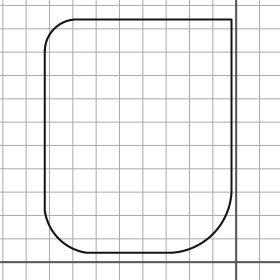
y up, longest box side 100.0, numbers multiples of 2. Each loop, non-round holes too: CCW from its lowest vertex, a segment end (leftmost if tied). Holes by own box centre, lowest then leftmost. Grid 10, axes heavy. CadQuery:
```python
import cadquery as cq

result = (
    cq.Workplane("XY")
    .moveTo(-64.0, 4.0)
    .lineTo(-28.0, 4.0)
    .threePointArc((-10.0, 12.0), (-2.0, 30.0))
    .lineTo(-2.0, 104.0)
    .lineTo(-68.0, 104.0)
    .threePointArc((-78.0, 100.0), (-82.0, 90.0))
    .lineTo(-82.0, 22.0)
    .threePointArc((-76.0, 10.0), (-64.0, 4.0))
    .close()
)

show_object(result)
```